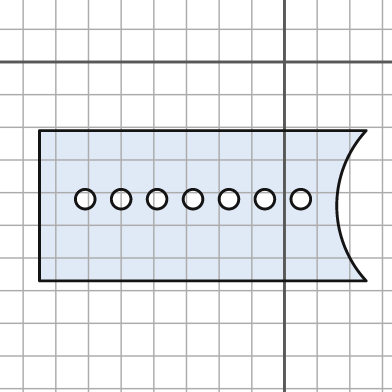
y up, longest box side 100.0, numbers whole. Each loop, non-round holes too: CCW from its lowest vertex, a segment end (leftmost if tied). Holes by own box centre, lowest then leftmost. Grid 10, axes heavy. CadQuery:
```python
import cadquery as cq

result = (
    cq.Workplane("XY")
    .moveTo(-75.0, -67.0)
    .lineTo(25.0, -67.0)
    .threePointArc((16.0, -44.0), (25.0, -21.0))
    .lineTo(-75.0, -21.0)
    .close()
    .moveTo(-61.0, -42.0)
    .circle(3.0)
    .moveTo(-50.0, -42.0)
    .circle(3.0)
    .moveTo(-39.0, -42.0)
    .circle(3.0)
    .moveTo(-28.0, -42.0)
    .circle(3.0)
    .moveTo(-17.0, -42.0)
    .circle(3.0)
    .moveTo(-6.0, -42.0)
    .circle(3.0)
    .moveTo(5.0, -42.0)
    .circle(3.0)
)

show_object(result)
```